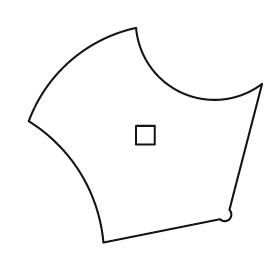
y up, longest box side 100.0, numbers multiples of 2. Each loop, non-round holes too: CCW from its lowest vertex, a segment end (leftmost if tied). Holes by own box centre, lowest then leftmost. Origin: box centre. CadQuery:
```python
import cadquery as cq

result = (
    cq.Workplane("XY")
    .moveTo(-18.0, -46.0)
    .lineTo(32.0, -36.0)
    .threePointArc((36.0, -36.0), (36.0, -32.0))
    .lineTo(50.0, 22.0)
    .threePointArc((16.0, 18.0), (-4.0, 46.0))
    .threePointArc((-32.0, 32.0), (-50.0, 6.0))
    .threePointArc((-28.0, -16.0), (-18.0, -46.0))
    .close()
    .moveTo(-4.0, -4.0)
    .lineTo(4.0, -4.0)
    .lineTo(4.0, 4.0)
    .lineTo(-4.0, 4.0)
    .close()
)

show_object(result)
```